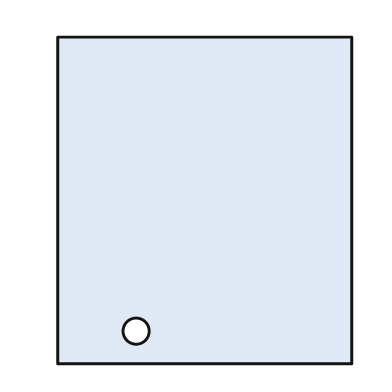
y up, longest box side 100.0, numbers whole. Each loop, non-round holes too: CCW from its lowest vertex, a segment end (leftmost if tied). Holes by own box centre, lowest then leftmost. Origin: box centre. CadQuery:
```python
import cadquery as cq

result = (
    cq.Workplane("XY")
    .moveTo(-45.0, -50.0)
    .lineTo(45.0, -50.0)
    .lineTo(45.0, 50.0)
    .lineTo(-45.0, 50.0)
    .close()
    .moveTo(-21.0, -40.0)
    .circle(4.0)
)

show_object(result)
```